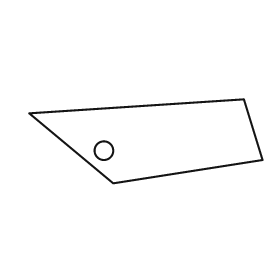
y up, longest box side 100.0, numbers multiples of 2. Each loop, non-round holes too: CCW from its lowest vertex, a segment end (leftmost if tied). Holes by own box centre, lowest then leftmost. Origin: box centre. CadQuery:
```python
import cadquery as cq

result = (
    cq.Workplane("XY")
    .moveTo(-14.0, -18.0)
    .lineTo(50.0, -8.0)
    .lineTo(42.0, 18.0)
    .lineTo(-50.0, 12.0)
    .close()
    .moveTo(-18.0, -4.0)
    .circle(4.0)
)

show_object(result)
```